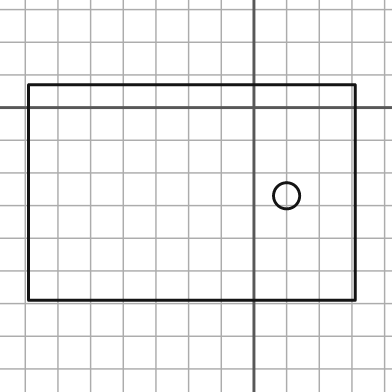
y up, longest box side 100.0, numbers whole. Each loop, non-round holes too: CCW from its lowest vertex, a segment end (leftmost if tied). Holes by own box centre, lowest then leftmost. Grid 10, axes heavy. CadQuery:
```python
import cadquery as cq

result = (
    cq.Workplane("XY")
    .moveTo(-69.0, -59.0)
    .lineTo(31.0, -59.0)
    .lineTo(31.0, 7.0)
    .lineTo(-69.0, 7.0)
    .close()
    .moveTo(10.0, -27.0)
    .circle(4.0)
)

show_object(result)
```